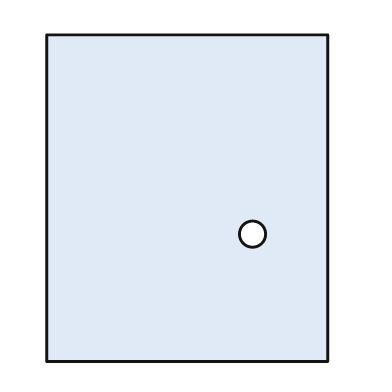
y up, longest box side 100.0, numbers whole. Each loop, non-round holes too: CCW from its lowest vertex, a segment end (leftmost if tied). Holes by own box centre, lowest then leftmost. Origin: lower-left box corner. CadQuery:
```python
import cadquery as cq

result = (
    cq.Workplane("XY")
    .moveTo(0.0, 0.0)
    .lineTo(86.0, 0.0)
    .lineTo(86.0, 100.0)
    .lineTo(0.0, 100.0)
    .close()
    .moveTo(63.0, 39.0)
    .circle(4.0)
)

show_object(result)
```